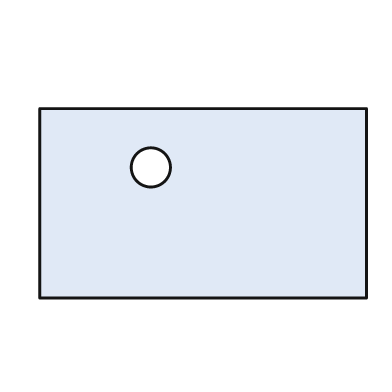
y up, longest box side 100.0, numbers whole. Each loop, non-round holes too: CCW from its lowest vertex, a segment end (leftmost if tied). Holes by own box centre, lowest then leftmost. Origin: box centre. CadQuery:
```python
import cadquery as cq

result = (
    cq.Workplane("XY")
    .moveTo(-50.0, -29.0)
    .lineTo(50.0, -29.0)
    .lineTo(50.0, 29.0)
    .lineTo(-50.0, 29.0)
    .close()
    .moveTo(-16.0, 11.0)
    .circle(6.0)
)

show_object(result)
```